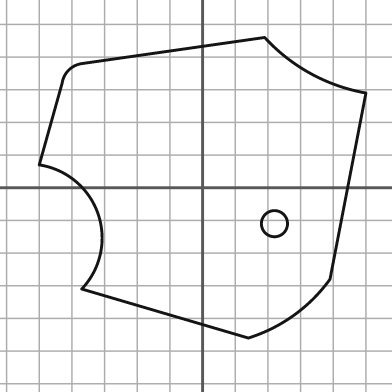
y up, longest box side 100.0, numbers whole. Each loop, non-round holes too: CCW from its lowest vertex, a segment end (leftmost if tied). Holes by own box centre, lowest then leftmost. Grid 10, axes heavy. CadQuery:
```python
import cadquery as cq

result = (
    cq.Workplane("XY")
    .moveTo(14.0, -46.0)
    .threePointArc((28.0, -39.0), (39.0, -28.0))
    .lineTo(50.0, 29.0)
    .threePointArc((33.0, 35.0), (19.0, 46.0))
    .lineTo(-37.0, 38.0)
    .threePointArc((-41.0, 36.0), (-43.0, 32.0))
    .lineTo(-50.0, 7.0)
    .threePointArc((-32.0, -8.0), (-37.0, -31.0))
    .close()
    .moveTo(22.0, -11.0)
    .circle(4.0)
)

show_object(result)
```